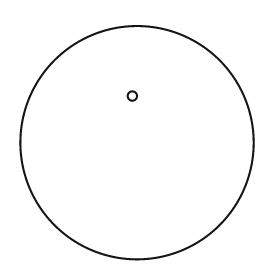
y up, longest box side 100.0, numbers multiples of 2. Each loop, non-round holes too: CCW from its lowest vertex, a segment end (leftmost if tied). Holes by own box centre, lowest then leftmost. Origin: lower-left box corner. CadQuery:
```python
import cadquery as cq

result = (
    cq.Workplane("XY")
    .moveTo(50.0, 50.0)
    .circle(50.0)
    .moveTo(48.0, 70.0)
    .circle(2.0)
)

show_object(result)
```